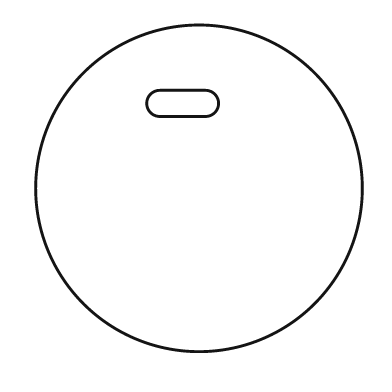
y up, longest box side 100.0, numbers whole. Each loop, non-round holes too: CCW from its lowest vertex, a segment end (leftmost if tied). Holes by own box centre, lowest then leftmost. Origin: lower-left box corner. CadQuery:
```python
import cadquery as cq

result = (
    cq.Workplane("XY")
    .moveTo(50.0, 50.0)
    .circle(50.0)
    .moveTo(38.0, 72.0)
    .lineTo(52.0, 72.0)
    .threePointArc((56.0, 76.0), (52.0, 80.0))
    .lineTo(38.0, 80.0)
    .threePointArc((34.0, 76.0), (38.0, 72.0))
    .close()
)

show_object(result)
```